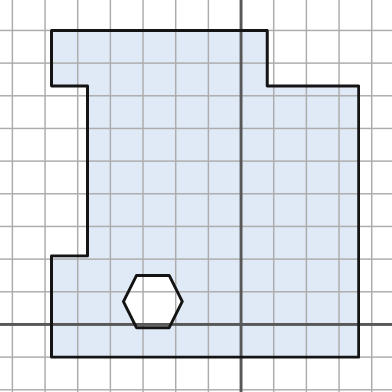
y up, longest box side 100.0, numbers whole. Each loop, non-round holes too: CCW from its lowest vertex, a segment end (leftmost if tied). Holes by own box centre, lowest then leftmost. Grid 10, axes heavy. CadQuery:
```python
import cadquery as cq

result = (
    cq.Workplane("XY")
    .moveTo(-58.0, -10.0)
    .lineTo(36.0, -10.0)
    .lineTo(36.0, 73.0)
    .lineTo(8.0, 73.0)
    .lineTo(8.0, 90.0)
    .lineTo(-58.0, 90.0)
    .lineTo(-58.0, 73.0)
    .lineTo(-47.0, 73.0)
    .lineTo(-47.0, 21.0)
    .lineTo(-58.0, 21.0)
    .close()
    .moveTo(-32.0, -1.0)
    .lineTo(-22.0, -1.0)
    .lineTo(-18.0, 7.0)
    .lineTo(-22.0, 15.0)
    .lineTo(-32.0, 15.0)
    .lineTo(-36.0, 7.0)
    .close()
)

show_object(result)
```